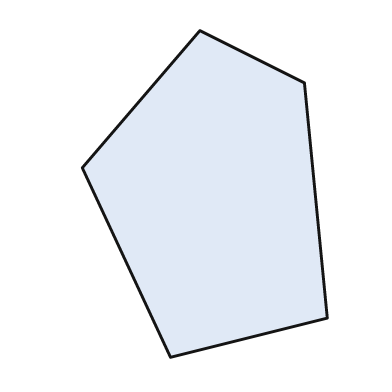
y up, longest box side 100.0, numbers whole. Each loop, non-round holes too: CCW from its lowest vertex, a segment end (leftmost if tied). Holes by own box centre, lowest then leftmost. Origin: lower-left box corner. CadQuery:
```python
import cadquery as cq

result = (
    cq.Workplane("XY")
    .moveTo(27.0, 0.0)
    .lineTo(75.0, 12.0)
    .lineTo(68.0, 84.0)
    .lineTo(36.0, 100.0)
    .lineTo(0.0, 58.0)
    .close()
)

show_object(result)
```